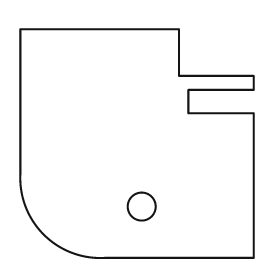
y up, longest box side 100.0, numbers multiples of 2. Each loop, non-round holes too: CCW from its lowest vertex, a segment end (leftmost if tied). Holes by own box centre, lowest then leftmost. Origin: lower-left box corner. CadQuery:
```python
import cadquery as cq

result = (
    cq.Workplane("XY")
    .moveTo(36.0, 0.0)
    .lineTo(100.0, 0.0)
    .lineTo(100.0, 62.0)
    .lineTo(72.0, 62.0)
    .lineTo(72.0, 72.0)
    .lineTo(100.0, 72.0)
    .lineTo(100.0, 78.0)
    .lineTo(68.0, 78.0)
    .lineTo(68.0, 98.0)
    .lineTo(0.0, 98.0)
    .lineTo(0.0, 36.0)
    .threePointArc((10.0, 10.0), (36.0, 0.0))
    .close()
    .moveTo(52.0, 22.0)
    .circle(6.0)
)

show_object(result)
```